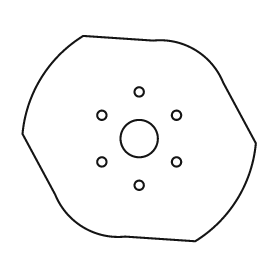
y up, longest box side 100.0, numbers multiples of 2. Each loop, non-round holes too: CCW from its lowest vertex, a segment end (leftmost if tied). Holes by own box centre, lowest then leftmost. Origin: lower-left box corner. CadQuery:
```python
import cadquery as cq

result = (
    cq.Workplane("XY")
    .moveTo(74.0, 0.0)
    .threePointArc((92.0, 18.0), (100.0, 42.0))
    .lineTo(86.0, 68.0)
    .threePointArc((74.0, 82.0), (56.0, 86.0))
    .lineTo(26.0, 88.0)
    .threePointArc((8.0, 70.0), (0.0, 46.0))
    .lineTo(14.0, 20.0)
    .threePointArc((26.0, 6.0), (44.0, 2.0))
    .close()
    .moveTo(50.0, 24.0)
    .circle(2.0)
    .moveTo(34.0, 34.0)
    .circle(2.0)
    .moveTo(66.0, 34.0)
    .circle(2.0)
    .moveTo(50.0, 44.0)
    .circle(8.0)
    .moveTo(34.0, 54.0)
    .circle(2.0)
    .moveTo(66.0, 54.0)
    .circle(2.0)
    .moveTo(50.0, 64.0)
    .circle(2.0)
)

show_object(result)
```